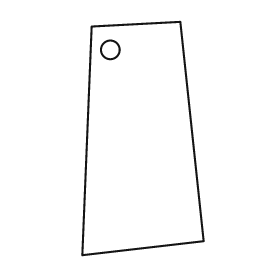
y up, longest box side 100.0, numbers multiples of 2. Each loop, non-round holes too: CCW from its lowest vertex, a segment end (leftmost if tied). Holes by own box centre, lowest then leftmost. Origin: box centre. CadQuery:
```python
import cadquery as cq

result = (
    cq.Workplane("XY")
    .moveTo(-26.0, -50.0)
    .lineTo(26.0, -44.0)
    .lineTo(16.0, 50.0)
    .lineTo(-22.0, 48.0)
    .close()
    .moveTo(-14.0, 38.0)
    .circle(4.0)
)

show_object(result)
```